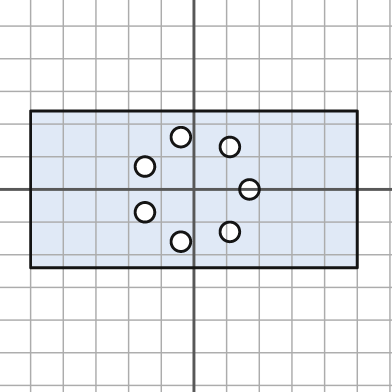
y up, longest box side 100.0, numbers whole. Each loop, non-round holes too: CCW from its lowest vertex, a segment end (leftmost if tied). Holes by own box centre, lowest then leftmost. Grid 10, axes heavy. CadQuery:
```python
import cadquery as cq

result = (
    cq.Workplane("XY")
    .moveTo(-50.0, -24.0)
    .lineTo(50.0, -24.0)
    .lineTo(50.0, 24.0)
    .lineTo(-50.0, 24.0)
    .close()
    .moveTo(-4.0, -16.0)
    .circle(3.0)
    .moveTo(11.0, -13.0)
    .circle(3.0)
    .moveTo(-15.0, -7.0)
    .circle(3.0)
    .moveTo(17.0, 0.0)
    .circle(3.0)
    .moveTo(-15.0, 7.0)
    .circle(3.0)
    .moveTo(11.0, 13.0)
    .circle(3.0)
    .moveTo(-4.0, 16.0)
    .circle(3.0)
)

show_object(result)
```